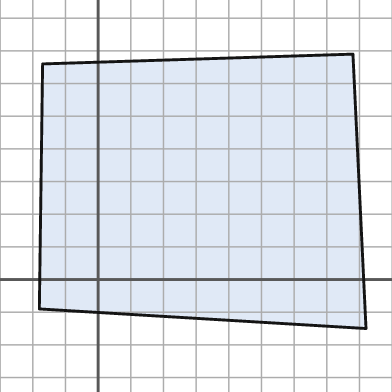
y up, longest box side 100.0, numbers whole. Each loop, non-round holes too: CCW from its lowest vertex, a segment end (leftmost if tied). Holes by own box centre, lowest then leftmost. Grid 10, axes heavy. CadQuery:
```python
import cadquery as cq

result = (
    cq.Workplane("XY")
    .moveTo(82.0, -15.0)
    .lineTo(78.0, 69.0)
    .lineTo(-17.0, 66.0)
    .lineTo(-18.0, -9.0)
    .close()
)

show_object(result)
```